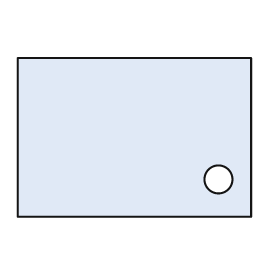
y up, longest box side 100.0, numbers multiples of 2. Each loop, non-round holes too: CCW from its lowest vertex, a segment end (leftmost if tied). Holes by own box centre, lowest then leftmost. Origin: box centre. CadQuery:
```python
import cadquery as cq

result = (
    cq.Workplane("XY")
    .moveTo(-50.0, -34.0)
    .lineTo(50.0, -34.0)
    .lineTo(50.0, 34.0)
    .lineTo(-50.0, 34.0)
    .close()
    .moveTo(36.0, -18.0)
    .circle(6.0)
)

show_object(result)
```